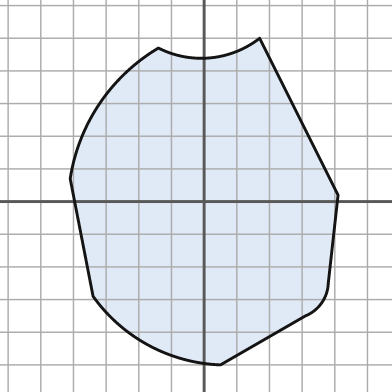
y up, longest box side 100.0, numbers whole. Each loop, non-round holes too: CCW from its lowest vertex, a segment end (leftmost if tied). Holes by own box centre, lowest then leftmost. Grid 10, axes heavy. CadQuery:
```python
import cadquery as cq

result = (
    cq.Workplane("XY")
    .moveTo(5.0, -50.0)
    .lineTo(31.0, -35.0)
    .threePointArc((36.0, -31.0), (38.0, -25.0))
    .lineTo(41.0, 2.0)
    .lineTo(17.0, 50.0)
    .threePointArc((2.0, 44.0), (-14.0, 47.0))
    .threePointArc((-32.0, 30.0), (-41.0, 7.0))
    .lineTo(-34.0, -29.0)
    .threePointArc((-17.0, -44.0), (5.0, -50.0))
    .close()
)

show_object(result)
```